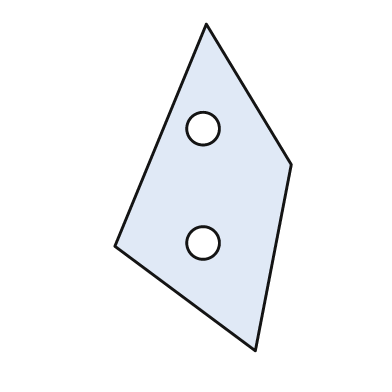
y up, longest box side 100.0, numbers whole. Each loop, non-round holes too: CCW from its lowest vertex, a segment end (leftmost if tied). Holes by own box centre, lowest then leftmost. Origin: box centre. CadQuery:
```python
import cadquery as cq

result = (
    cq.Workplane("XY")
    .moveTo(16.0, -50.0)
    .lineTo(27.0, 7.0)
    .lineTo(1.0, 50.0)
    .lineTo(-27.0, -18.0)
    .close()
    .moveTo(0.0, -17.0)
    .circle(5.0)
    .moveTo(0.0, 18.0)
    .circle(5.0)
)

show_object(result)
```